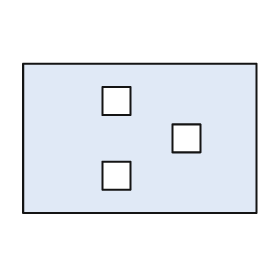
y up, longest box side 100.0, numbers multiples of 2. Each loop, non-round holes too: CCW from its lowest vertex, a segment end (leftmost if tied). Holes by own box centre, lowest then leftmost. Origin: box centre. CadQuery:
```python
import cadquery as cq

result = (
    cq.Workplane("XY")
    .moveTo(-50.0, -32.0)
    .lineTo(50.0, -32.0)
    .lineTo(50.0, 32.0)
    .lineTo(-50.0, 32.0)
    .close()
    .moveTo(-16.0, -22.0)
    .lineTo(-4.0, -22.0)
    .lineTo(-4.0, -10.0)
    .lineTo(-16.0, -10.0)
    .close()
    .moveTo(14.0, -6.0)
    .lineTo(26.0, -6.0)
    .lineTo(26.0, 6.0)
    .lineTo(14.0, 6.0)
    .close()
    .moveTo(-16.0, 10.0)
    .lineTo(-4.0, 10.0)
    .lineTo(-4.0, 22.0)
    .lineTo(-16.0, 22.0)
    .close()
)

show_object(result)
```